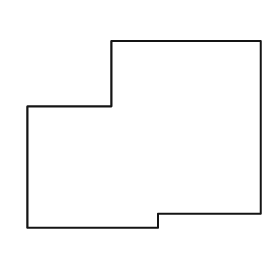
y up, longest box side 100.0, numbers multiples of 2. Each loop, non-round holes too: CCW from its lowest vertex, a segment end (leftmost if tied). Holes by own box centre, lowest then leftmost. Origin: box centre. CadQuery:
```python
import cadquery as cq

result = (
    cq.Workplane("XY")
    .moveTo(-50.0, -40.0)
    .lineTo(6.0, -40.0)
    .lineTo(6.0, -34.0)
    .lineTo(50.0, -34.0)
    .lineTo(50.0, 40.0)
    .lineTo(-14.0, 40.0)
    .lineTo(-14.0, 12.0)
    .lineTo(-50.0, 12.0)
    .close()
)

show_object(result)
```